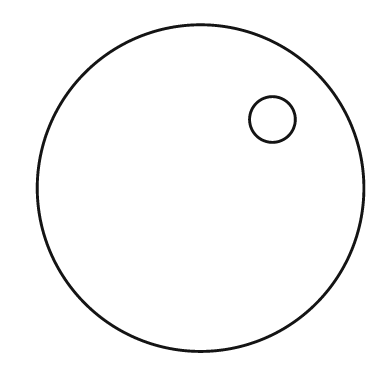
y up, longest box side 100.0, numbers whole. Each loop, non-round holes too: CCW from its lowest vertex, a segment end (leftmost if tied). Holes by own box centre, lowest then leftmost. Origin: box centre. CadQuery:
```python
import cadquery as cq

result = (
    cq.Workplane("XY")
    .moveTo(0.0, 0.0)
    .circle(50.0)
    .moveTo(22.0, 21.0)
    .circle(7.0)
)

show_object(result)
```